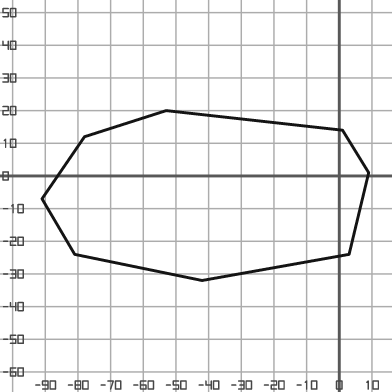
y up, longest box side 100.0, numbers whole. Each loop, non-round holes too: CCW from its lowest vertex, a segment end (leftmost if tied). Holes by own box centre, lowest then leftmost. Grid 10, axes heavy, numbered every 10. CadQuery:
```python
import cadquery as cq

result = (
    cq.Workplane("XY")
    .moveTo(-42.0, -32.0)
    .lineTo(3.0, -24.0)
    .lineTo(9.0, 1.0)
    .lineTo(1.0, 14.0)
    .lineTo(-53.0, 20.0)
    .lineTo(-78.0, 12.0)
    .lineTo(-91.0, -7.0)
    .lineTo(-81.0, -24.0)
    .close()
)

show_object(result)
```